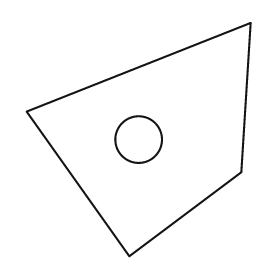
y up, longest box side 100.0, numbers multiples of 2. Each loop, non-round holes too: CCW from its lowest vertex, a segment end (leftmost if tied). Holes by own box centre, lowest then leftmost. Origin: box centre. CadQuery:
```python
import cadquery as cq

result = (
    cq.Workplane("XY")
    .moveTo(-4.0, -50.0)
    .lineTo(44.0, -14.0)
    .lineTo(48.0, 50.0)
    .lineTo(-48.0, 12.0)
    .close()
    .moveTo(0.0, 0.0)
    .circle(10.0)
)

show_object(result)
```